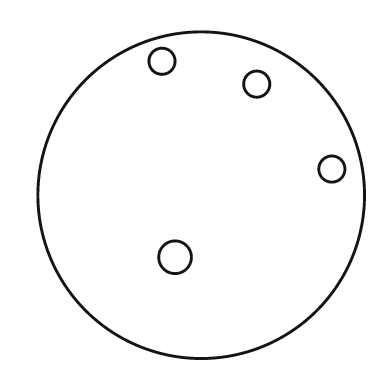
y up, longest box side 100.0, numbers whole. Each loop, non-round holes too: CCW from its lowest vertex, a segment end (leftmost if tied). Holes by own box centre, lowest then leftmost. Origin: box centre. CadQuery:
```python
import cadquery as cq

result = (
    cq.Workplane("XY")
    .moveTo(0.0, 0.0)
    .circle(50.0)
    .moveTo(-8.0, -19.0)
    .circle(5.0)
    .moveTo(40.0, 8.0)
    .circle(4.0)
    .moveTo(17.0, 34.0)
    .circle(4.0)
    .moveTo(-12.0, 41.0)
    .circle(4.0)
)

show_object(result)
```